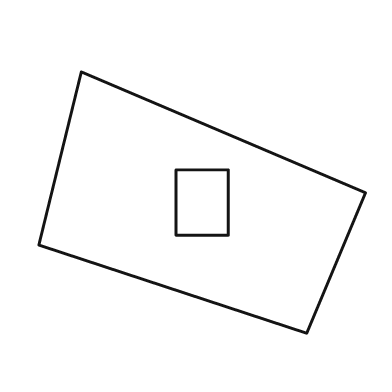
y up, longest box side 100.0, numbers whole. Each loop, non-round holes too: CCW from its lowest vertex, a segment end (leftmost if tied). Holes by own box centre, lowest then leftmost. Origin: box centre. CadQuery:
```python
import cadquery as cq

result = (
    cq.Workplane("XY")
    .moveTo(32.0, -40.0)
    .lineTo(50.0, 3.0)
    .lineTo(-37.0, 40.0)
    .lineTo(-50.0, -13.0)
    .close()
    .moveTo(-8.0, -10.0)
    .lineTo(8.0, -10.0)
    .lineTo(8.0, 10.0)
    .lineTo(-8.0, 10.0)
    .close()
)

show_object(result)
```